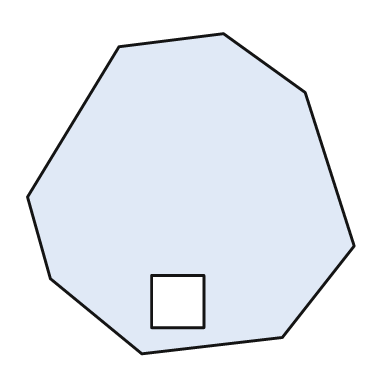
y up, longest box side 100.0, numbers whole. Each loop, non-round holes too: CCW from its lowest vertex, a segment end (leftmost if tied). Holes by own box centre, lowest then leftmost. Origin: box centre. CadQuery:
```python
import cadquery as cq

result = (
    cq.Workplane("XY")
    .moveTo(-15.0, -49.0)
    .lineTo(28.0, -44.0)
    .lineTo(50.0, -16.0)
    .lineTo(35.0, 31.0)
    .lineTo(10.0, 49.0)
    .lineTo(-22.0, 45.0)
    .lineTo(-50.0, -1.0)
    .lineTo(-43.0, -26.0)
    .close()
    .moveTo(-12.0, -41.0)
    .lineTo(4.0, -41.0)
    .lineTo(4.0, -25.0)
    .lineTo(-12.0, -25.0)
    .close()
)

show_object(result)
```